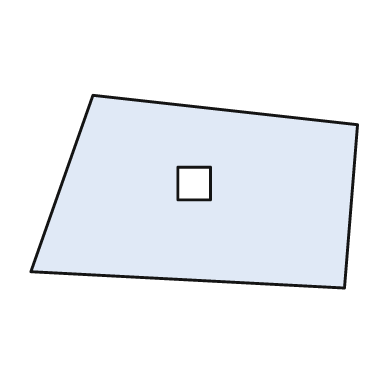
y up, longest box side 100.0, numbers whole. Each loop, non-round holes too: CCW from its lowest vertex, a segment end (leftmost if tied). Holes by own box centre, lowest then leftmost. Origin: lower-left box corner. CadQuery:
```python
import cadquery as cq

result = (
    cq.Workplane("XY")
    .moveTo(96.0, 0.0)
    .lineTo(100.0, 50.0)
    .lineTo(19.0, 59.0)
    .lineTo(0.0, 5.0)
    .close()
    .moveTo(45.0, 27.0)
    .lineTo(55.0, 27.0)
    .lineTo(55.0, 37.0)
    .lineTo(45.0, 37.0)
    .close()
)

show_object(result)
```